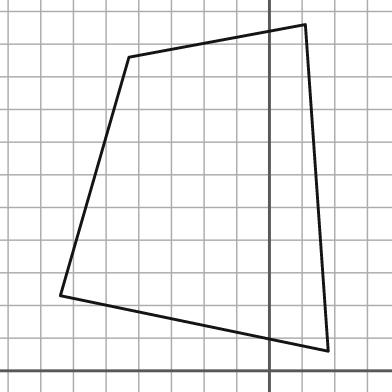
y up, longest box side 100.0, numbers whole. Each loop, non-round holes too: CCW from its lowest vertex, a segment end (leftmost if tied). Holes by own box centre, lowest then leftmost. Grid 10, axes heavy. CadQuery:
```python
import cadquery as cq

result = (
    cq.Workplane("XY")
    .moveTo(18.0, 6.0)
    .lineTo(11.0, 106.0)
    .lineTo(-43.0, 96.0)
    .lineTo(-64.0, 23.0)
    .close()
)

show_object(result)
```